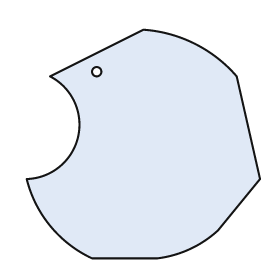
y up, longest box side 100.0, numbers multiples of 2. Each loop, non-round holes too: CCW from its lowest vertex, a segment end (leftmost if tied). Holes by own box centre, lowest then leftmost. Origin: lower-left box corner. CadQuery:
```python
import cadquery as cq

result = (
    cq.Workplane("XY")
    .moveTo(28.0, 0.0)
    .lineTo(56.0, 0.0)
    .threePointArc((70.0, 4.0), (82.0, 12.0))
    .lineTo(100.0, 34.0)
    .lineTo(90.0, 78.0)
    .threePointArc((72.0, 92.0), (50.0, 98.0))
    .lineTo(10.0, 78.0)
    .threePointArc((22.0, 52.0), (0.0, 34.0))
    .threePointArc((10.0, 14.0), (28.0, 0.0))
    .close()
    .moveTo(30.0, 80.0)
    .circle(2.0)
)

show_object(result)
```